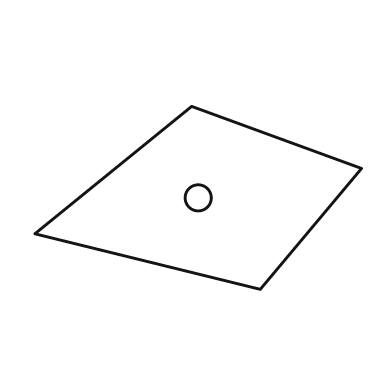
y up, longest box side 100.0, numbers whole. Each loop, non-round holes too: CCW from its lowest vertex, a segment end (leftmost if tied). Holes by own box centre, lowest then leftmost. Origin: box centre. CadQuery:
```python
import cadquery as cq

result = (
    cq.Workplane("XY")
    .moveTo(19.0, -28.0)
    .lineTo(50.0, 9.0)
    .lineTo(-2.0, 28.0)
    .lineTo(-50.0, -11.0)
    .close()
    .moveTo(0.0, 0.0)
    .circle(4.0)
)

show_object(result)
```